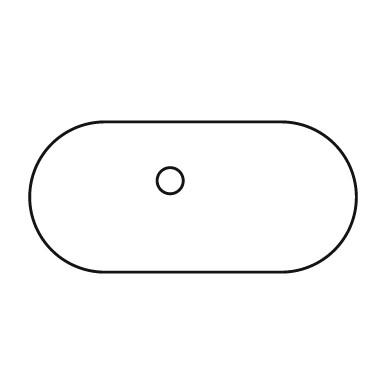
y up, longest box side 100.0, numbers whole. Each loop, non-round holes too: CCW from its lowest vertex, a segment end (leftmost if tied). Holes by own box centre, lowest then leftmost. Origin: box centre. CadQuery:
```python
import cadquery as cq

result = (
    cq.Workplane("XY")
    .moveTo(-27.0, -23.0)
    .lineTo(27.0, -23.0)
    .threePointArc((50.0, 0.0), (27.0, 23.0))
    .lineTo(-27.0, 23.0)
    .threePointArc((-50.0, 0.0), (-27.0, -23.0))
    .close()
    .moveTo(-7.0, 5.0)
    .circle(4.0)
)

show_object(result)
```